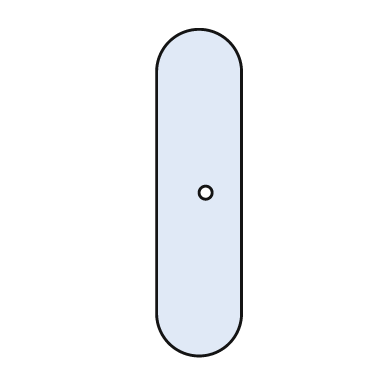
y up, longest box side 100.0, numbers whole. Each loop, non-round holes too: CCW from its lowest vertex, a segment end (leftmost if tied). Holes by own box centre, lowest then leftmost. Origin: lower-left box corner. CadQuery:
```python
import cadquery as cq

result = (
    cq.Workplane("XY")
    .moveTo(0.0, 13.0)
    .threePointArc((13.0, 0.0), (26.0, 13.0))
    .lineTo(26.0, 87.0)
    .threePointArc((13.0, 100.0), (0.0, 87.0))
    .close()
    .moveTo(15.0, 50.0)
    .circle(2.0)
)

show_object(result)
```